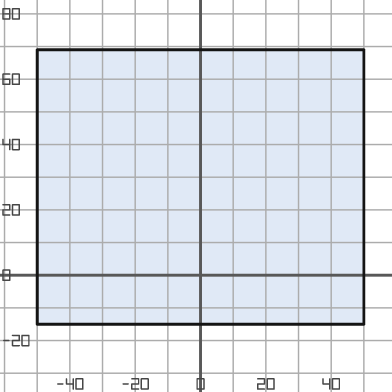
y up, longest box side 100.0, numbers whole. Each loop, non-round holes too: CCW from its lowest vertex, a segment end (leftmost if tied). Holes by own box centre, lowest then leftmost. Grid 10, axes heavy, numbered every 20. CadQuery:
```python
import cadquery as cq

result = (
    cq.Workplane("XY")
    .moveTo(-50.0, -15.0)
    .lineTo(50.0, -15.0)
    .lineTo(50.0, 69.0)
    .lineTo(-50.0, 69.0)
    .close()
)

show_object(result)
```